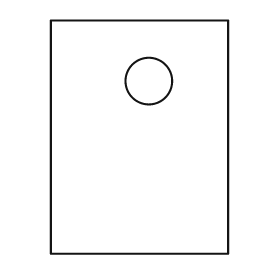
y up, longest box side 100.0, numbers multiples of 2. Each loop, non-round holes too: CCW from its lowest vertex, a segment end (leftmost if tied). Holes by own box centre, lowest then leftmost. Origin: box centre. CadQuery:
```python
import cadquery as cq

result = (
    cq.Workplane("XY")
    .moveTo(-38.0, -50.0)
    .lineTo(38.0, -50.0)
    .lineTo(38.0, 50.0)
    .lineTo(-38.0, 50.0)
    .close()
    .moveTo(4.0, 24.0)
    .circle(10.0)
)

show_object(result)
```